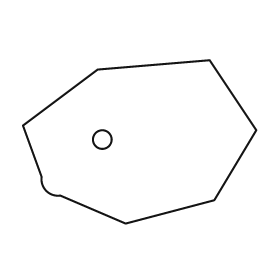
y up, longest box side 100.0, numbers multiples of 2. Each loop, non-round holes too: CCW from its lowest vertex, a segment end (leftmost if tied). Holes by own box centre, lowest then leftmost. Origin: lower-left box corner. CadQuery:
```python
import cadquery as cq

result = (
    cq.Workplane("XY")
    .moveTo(44.0, 0.0)
    .lineTo(82.0, 10.0)
    .lineTo(100.0, 40.0)
    .lineTo(80.0, 70.0)
    .lineTo(32.0, 66.0)
    .lineTo(0.0, 42.0)
    .lineTo(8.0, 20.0)
    .threePointArc((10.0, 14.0), (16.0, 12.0))
    .close()
    .moveTo(34.0, 36.0)
    .circle(4.0)
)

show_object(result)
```